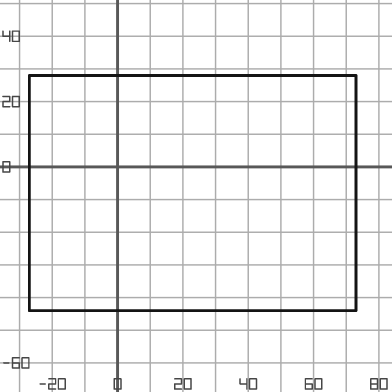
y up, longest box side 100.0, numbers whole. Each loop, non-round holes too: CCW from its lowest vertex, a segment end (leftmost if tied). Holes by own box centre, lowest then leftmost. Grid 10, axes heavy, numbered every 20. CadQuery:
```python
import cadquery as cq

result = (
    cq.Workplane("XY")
    .moveTo(-27.0, -44.0)
    .lineTo(73.0, -44.0)
    .lineTo(73.0, 28.0)
    .lineTo(-27.0, 28.0)
    .close()
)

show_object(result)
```